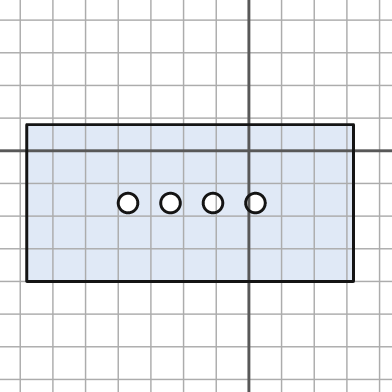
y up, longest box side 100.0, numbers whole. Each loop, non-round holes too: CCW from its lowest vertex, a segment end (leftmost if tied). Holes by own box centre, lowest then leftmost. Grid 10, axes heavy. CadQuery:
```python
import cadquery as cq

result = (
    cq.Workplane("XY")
    .moveTo(-68.0, -40.0)
    .lineTo(32.0, -40.0)
    .lineTo(32.0, 8.0)
    .lineTo(-68.0, 8.0)
    .close()
    .moveTo(-37.0, -16.0)
    .circle(3.0)
    .moveTo(-24.0, -16.0)
    .circle(3.0)
    .moveTo(-11.0, -16.0)
    .circle(3.0)
    .moveTo(2.0, -16.0)
    .circle(3.0)
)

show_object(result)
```